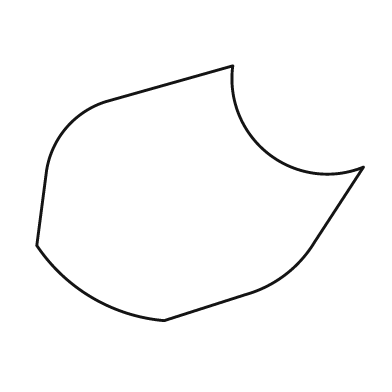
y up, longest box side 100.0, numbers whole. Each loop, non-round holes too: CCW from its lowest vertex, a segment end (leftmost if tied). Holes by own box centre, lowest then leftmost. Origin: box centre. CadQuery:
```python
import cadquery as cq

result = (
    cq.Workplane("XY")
    .moveTo(-11.0, -39.0)
    .lineTo(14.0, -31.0)
    .threePointArc((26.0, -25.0), (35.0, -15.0))
    .lineTo(50.0, 8.0)
    .threePointArc((21.0, 12.0), (10.0, 39.0))
    .lineTo(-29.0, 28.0)
    .threePointArc((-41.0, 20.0), (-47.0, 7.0))
    .lineTo(-50.0, -16.0)
    .threePointArc((-33.0, -32.0), (-11.0, -39.0))
    .close()
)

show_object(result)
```